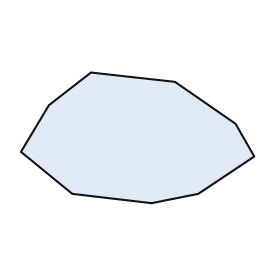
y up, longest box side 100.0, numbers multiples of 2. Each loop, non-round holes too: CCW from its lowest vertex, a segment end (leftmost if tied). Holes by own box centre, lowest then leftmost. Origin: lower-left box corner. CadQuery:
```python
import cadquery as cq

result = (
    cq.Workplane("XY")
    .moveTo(56.0, 0.0)
    .lineTo(76.0, 4.0)
    .lineTo(100.0, 20.0)
    .lineTo(92.0, 34.0)
    .lineTo(66.0, 52.0)
    .lineTo(30.0, 56.0)
    .lineTo(12.0, 42.0)
    .lineTo(0.0, 22.0)
    .lineTo(22.0, 4.0)
    .close()
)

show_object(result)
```